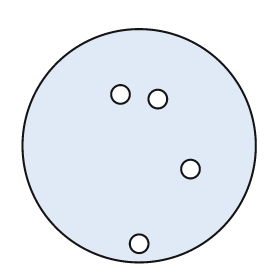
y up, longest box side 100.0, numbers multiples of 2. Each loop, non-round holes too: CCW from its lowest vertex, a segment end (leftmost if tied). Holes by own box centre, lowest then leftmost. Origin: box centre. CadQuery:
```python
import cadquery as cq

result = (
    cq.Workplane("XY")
    .moveTo(0.0, 0.0)
    .circle(50.0)
    .moveTo(0.0, -42.0)
    .circle(4.0)
    .moveTo(22.0, -10.0)
    .circle(4.0)
    .moveTo(8.0, 20.0)
    .circle(4.0)
    .moveTo(-8.0, 22.0)
    .circle(4.0)
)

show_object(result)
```